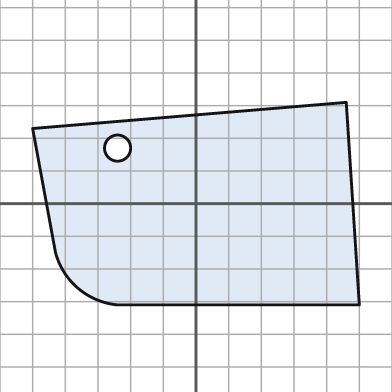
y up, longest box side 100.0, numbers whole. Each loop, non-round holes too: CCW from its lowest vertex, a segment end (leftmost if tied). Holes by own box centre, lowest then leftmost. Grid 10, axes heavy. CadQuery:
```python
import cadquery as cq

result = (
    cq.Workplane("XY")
    .moveTo(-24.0, -31.0)
    .lineTo(50.0, -31.0)
    .lineTo(46.0, 31.0)
    .lineTo(-50.0, 23.0)
    .lineTo(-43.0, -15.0)
    .threePointArc((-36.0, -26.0), (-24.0, -31.0))
    .close()
    .moveTo(-24.0, 17.0)
    .circle(4.0)
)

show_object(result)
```